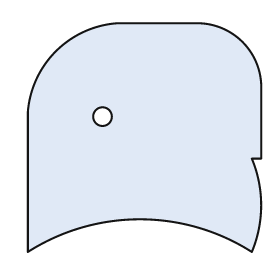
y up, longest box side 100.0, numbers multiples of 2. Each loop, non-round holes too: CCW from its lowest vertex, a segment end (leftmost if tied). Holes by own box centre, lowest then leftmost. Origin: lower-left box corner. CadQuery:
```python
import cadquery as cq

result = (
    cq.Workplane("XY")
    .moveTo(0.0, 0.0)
    .threePointArc((48.0, 14.0), (96.0, 0.0))
    .threePointArc((100.0, 20.0), (96.0, 40.0))
    .lineTo(100.0, 40.0)
    .lineTo(100.0, 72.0)
    .threePointArc((92.0, 90.0), (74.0, 98.0))
    .lineTo(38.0, 98.0)
    .threePointArc((12.0, 86.0), (0.0, 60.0))
    .close()
    .moveTo(32.0, 58.0)
    .circle(4.0)
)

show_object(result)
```